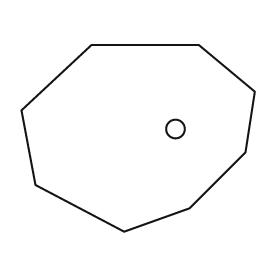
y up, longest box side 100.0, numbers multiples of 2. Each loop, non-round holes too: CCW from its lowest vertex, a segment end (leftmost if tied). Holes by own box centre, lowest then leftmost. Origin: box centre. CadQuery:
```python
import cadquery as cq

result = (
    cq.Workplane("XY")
    .moveTo(-6.0, -40.0)
    .lineTo(22.0, -30.0)
    .lineTo(46.0, -6.0)
    .lineTo(50.0, 20.0)
    .lineTo(26.0, 40.0)
    .lineTo(-20.0, 40.0)
    .lineTo(-50.0, 12.0)
    .lineTo(-44.0, -20.0)
    .close()
    .moveTo(16.0, 4.0)
    .circle(4.0)
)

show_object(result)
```